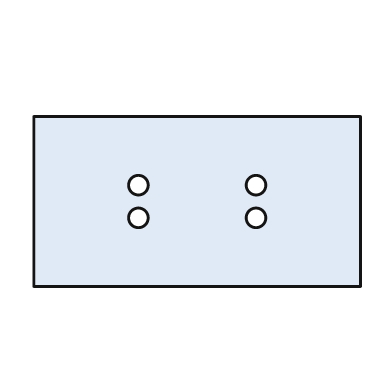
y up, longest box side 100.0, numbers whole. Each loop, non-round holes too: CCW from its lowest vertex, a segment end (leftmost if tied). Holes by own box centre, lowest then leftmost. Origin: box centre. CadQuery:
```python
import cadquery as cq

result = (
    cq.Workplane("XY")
    .moveTo(-50.0, -26.0)
    .lineTo(50.0, -26.0)
    .lineTo(50.0, 26.0)
    .lineTo(-50.0, 26.0)
    .close()
    .moveTo(-18.0, -5.0)
    .circle(3.0)
    .moveTo(18.0, -5.0)
    .circle(3.0)
    .moveTo(-18.0, 5.0)
    .circle(3.0)
    .moveTo(18.0, 5.0)
    .circle(3.0)
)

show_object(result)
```